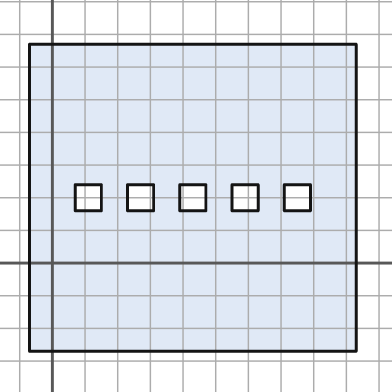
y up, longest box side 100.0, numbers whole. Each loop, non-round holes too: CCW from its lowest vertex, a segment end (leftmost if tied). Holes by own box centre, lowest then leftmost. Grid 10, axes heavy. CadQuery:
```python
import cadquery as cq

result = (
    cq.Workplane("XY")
    .moveTo(-7.0, -27.0)
    .lineTo(93.0, -27.0)
    .lineTo(93.0, 67.0)
    .lineTo(-7.0, 67.0)
    .close()
    .moveTo(7.0, 16.0)
    .lineTo(15.0, 16.0)
    .lineTo(15.0, 24.0)
    .lineTo(7.0, 24.0)
    .close()
    .moveTo(23.0, 16.0)
    .lineTo(31.0, 16.0)
    .lineTo(31.0, 24.0)
    .lineTo(23.0, 24.0)
    .close()
    .moveTo(39.0, 16.0)
    .lineTo(47.0, 16.0)
    .lineTo(47.0, 24.0)
    .lineTo(39.0, 24.0)
    .close()
    .moveTo(55.0, 16.0)
    .lineTo(63.0, 16.0)
    .lineTo(63.0, 24.0)
    .lineTo(55.0, 24.0)
    .close()
    .moveTo(71.0, 16.0)
    .lineTo(79.0, 16.0)
    .lineTo(79.0, 24.0)
    .lineTo(71.0, 24.0)
    .close()
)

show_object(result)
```